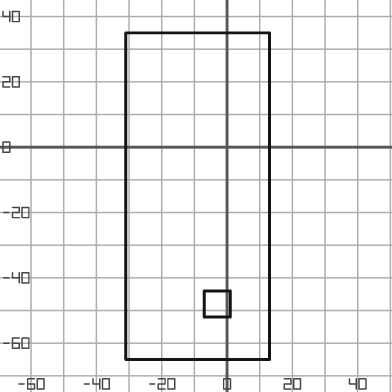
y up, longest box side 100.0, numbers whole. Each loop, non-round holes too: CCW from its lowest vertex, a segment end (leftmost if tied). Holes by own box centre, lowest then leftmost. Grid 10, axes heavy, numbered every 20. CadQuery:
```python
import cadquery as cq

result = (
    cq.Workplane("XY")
    .moveTo(-31.0, -65.0)
    .lineTo(13.0, -65.0)
    .lineTo(13.0, 35.0)
    .lineTo(-31.0, 35.0)
    .close()
    .moveTo(-7.0, -52.0)
    .lineTo(1.0, -52.0)
    .lineTo(1.0, -44.0)
    .lineTo(-7.0, -44.0)
    .close()
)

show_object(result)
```